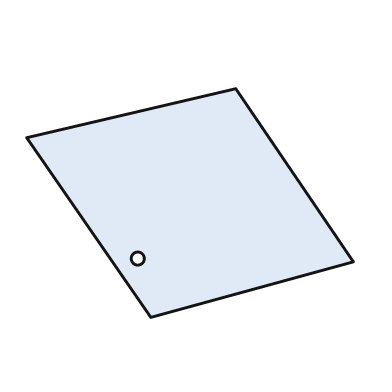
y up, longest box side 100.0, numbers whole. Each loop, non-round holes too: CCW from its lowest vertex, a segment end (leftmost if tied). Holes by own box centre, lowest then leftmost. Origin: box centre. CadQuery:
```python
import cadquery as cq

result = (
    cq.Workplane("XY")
    .moveTo(-12.0, -35.0)
    .lineTo(50.0, -18.0)
    .lineTo(14.0, 35.0)
    .lineTo(-50.0, 20.0)
    .close()
    .moveTo(-16.0, -17.0)
    .circle(2.0)
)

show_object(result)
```